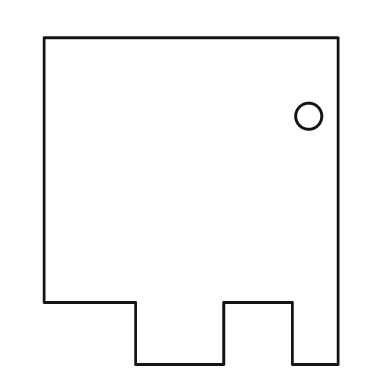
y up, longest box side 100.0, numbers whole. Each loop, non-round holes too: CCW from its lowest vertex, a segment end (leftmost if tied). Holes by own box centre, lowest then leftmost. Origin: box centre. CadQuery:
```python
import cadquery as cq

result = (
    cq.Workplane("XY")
    .moveTo(-17.0, -50.0)
    .lineTo(10.0, -50.0)
    .lineTo(10.0, -31.0)
    .lineTo(31.0, -31.0)
    .lineTo(31.0, -50.0)
    .lineTo(45.0, -50.0)
    .lineTo(45.0, 50.0)
    .lineTo(-45.0, 50.0)
    .lineTo(-45.0, -31.0)
    .lineTo(-17.0, -31.0)
    .close()
    .moveTo(36.0, 26.0)
    .circle(4.0)
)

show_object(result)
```